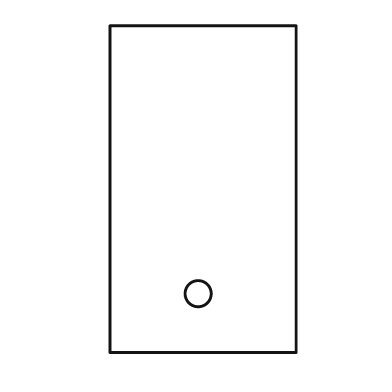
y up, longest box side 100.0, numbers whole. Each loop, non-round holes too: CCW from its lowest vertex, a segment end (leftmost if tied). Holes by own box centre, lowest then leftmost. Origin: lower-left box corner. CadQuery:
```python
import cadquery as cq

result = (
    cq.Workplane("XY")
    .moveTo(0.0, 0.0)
    .lineTo(57.0, 0.0)
    .lineTo(57.0, 100.0)
    .lineTo(0.0, 100.0)
    .close()
    .moveTo(27.0, 18.0)
    .circle(4.0)
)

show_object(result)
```